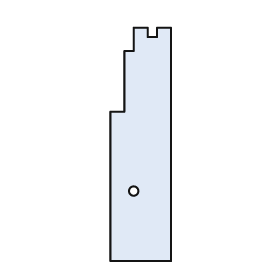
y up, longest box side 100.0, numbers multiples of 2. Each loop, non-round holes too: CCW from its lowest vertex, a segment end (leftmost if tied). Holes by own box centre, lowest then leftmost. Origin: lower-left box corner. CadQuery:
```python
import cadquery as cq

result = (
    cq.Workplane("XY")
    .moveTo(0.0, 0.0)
    .lineTo(26.0, 0.0)
    .lineTo(26.0, 100.0)
    .lineTo(20.0, 100.0)
    .lineTo(20.0, 96.0)
    .lineTo(16.0, 96.0)
    .lineTo(16.0, 100.0)
    .lineTo(10.0, 100.0)
    .lineTo(10.0, 90.0)
    .lineTo(6.0, 90.0)
    .lineTo(6.0, 64.0)
    .lineTo(0.0, 64.0)
    .close()
    .moveTo(10.0, 30.0)
    .circle(2.0)
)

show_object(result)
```